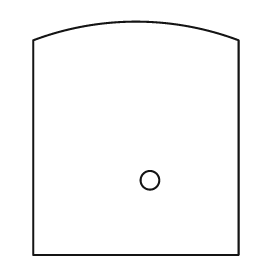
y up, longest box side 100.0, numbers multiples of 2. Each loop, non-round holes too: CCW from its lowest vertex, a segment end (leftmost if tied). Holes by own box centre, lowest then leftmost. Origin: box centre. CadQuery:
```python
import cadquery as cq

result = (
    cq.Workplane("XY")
    .moveTo(-44.0, -50.0)
    .lineTo(44.0, -50.0)
    .lineTo(44.0, 42.0)
    .threePointArc((0.0, 50.0), (-44.0, 42.0))
    .close()
    .moveTo(6.0, -18.0)
    .circle(4.0)
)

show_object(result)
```